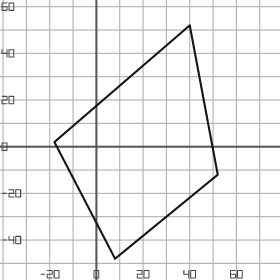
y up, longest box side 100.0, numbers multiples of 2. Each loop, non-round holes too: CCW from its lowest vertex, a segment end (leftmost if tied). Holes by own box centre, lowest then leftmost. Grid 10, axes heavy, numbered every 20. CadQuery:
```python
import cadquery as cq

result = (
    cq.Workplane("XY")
    .moveTo(8.0, -48.0)
    .lineTo(52.0, -12.0)
    .lineTo(40.0, 52.0)
    .lineTo(-18.0, 2.0)
    .close()
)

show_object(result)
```